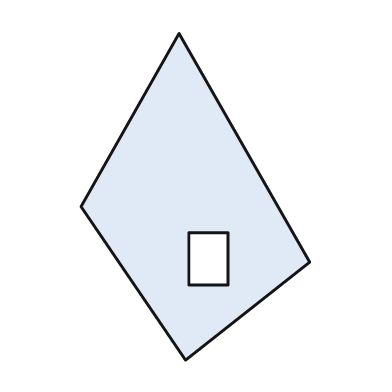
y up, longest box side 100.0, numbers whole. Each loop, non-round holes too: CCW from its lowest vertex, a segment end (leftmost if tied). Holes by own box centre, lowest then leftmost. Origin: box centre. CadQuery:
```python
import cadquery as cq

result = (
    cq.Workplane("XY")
    .moveTo(-3.0, -50.0)
    .lineTo(35.0, -20.0)
    .lineTo(-5.0, 50.0)
    .lineTo(-35.0, -3.0)
    .close()
    .moveTo(-2.0, -27.0)
    .lineTo(10.0, -27.0)
    .lineTo(10.0, -11.0)
    .lineTo(-2.0, -11.0)
    .close()
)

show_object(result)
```